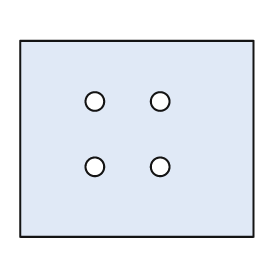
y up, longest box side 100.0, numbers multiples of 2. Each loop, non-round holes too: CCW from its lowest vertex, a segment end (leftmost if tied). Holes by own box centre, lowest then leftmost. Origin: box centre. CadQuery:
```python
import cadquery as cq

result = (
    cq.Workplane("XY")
    .moveTo(-50.0, -42.0)
    .lineTo(50.0, -42.0)
    .lineTo(50.0, 42.0)
    .lineTo(-50.0, 42.0)
    .close()
    .moveTo(-18.0, -12.0)
    .circle(4.0)
    .moveTo(10.0, -12.0)
    .circle(4.0)
    .moveTo(-18.0, 16.0)
    .circle(4.0)
    .moveTo(10.0, 16.0)
    .circle(4.0)
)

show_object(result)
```